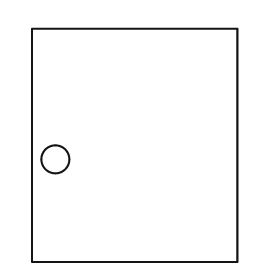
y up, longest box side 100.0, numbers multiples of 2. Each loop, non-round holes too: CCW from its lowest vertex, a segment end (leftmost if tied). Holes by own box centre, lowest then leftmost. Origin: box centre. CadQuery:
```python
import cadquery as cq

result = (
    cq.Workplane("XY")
    .moveTo(-44.0, -50.0)
    .lineTo(44.0, -50.0)
    .lineTo(44.0, 50.0)
    .lineTo(-44.0, 50.0)
    .close()
    .moveTo(-34.0, -6.0)
    .circle(6.0)
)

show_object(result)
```